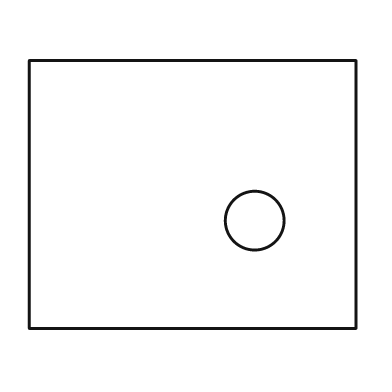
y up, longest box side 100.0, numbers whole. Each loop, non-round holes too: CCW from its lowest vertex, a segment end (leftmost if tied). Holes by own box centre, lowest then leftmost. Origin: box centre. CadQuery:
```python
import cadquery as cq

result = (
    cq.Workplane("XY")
    .moveTo(-50.0, -41.0)
    .lineTo(50.0, -41.0)
    .lineTo(50.0, 41.0)
    .lineTo(-50.0, 41.0)
    .close()
    .moveTo(19.0, -8.0)
    .circle(9.0)
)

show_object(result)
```